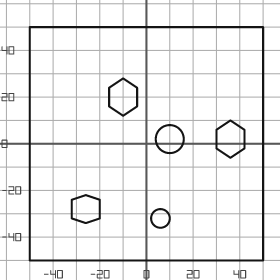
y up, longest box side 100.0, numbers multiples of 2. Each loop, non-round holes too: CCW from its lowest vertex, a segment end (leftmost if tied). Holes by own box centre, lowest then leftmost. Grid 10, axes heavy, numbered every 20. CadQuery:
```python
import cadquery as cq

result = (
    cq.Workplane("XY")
    .moveTo(-50.0, -50.0)
    .lineTo(50.0, -50.0)
    .lineTo(50.0, 50.0)
    .lineTo(-50.0, 50.0)
    .close()
    .moveTo(6.0, -32.0)
    .circle(4.0)
    .moveTo(-26.0, -34.0)
    .lineTo(-20.0, -32.0)
    .lineTo(-20.0, -24.0)
    .lineTo(-26.0, -22.0)
    .lineTo(-32.0, -24.0)
    .lineTo(-32.0, -32.0)
    .close()
    .moveTo(10.0, 2.0)
    .circle(6.0)
    .moveTo(36.0, -6.0)
    .lineTo(42.0, -2.0)
    .lineTo(42.0, 6.0)
    .lineTo(36.0, 10.0)
    .lineTo(30.0, 6.0)
    .lineTo(30.0, -2.0)
    .close()
    .moveTo(-10.0, 12.0)
    .lineTo(-4.0, 16.0)
    .lineTo(-4.0, 24.0)
    .lineTo(-10.0, 28.0)
    .lineTo(-16.0, 24.0)
    .lineTo(-16.0, 16.0)
    .close()
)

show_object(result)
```